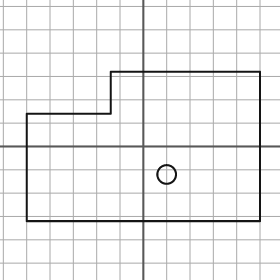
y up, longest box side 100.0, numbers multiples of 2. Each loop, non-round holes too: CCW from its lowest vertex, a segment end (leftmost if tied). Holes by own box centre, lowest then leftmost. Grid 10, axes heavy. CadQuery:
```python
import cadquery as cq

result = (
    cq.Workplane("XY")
    .moveTo(-50.0, -32.0)
    .lineTo(50.0, -32.0)
    .lineTo(50.0, 32.0)
    .lineTo(-14.0, 32.0)
    .lineTo(-14.0, 14.0)
    .lineTo(-50.0, 14.0)
    .close()
    .moveTo(10.0, -12.0)
    .circle(4.0)
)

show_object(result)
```